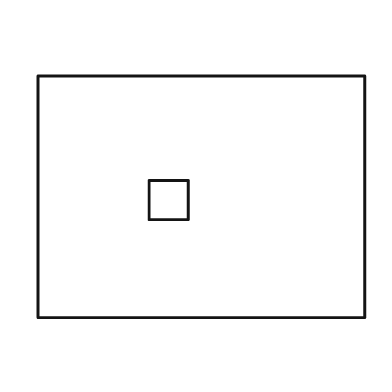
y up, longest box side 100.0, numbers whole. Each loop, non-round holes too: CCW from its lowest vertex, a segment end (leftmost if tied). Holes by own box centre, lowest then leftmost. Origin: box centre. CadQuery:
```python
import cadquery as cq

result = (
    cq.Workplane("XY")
    .moveTo(-50.0, -37.0)
    .lineTo(50.0, -37.0)
    .lineTo(50.0, 37.0)
    .lineTo(-50.0, 37.0)
    .close()
    .moveTo(-16.0, -7.0)
    .lineTo(-4.0, -7.0)
    .lineTo(-4.0, 5.0)
    .lineTo(-16.0, 5.0)
    .close()
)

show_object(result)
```